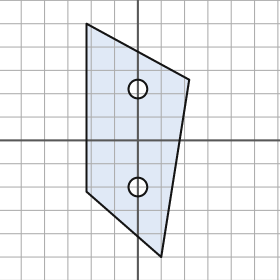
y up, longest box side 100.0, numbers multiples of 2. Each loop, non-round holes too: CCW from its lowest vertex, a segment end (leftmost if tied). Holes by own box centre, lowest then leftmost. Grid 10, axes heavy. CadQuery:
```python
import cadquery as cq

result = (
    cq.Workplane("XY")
    .moveTo(10.0, -50.0)
    .lineTo(22.0, 26.0)
    .lineTo(-22.0, 50.0)
    .lineTo(-22.0, -22.0)
    .close()
    .moveTo(0.0, -20.0)
    .circle(4.0)
    .moveTo(0.0, 22.0)
    .circle(4.0)
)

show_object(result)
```